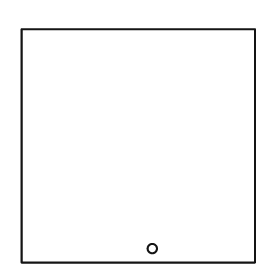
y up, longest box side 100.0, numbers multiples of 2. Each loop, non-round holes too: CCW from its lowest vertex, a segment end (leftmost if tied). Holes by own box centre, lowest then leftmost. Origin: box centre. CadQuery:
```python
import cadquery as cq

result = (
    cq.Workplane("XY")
    .moveTo(-50.0, -50.0)
    .lineTo(50.0, -50.0)
    .lineTo(50.0, 50.0)
    .lineTo(-50.0, 50.0)
    .close()
    .moveTo(6.0, -44.0)
    .circle(2.0)
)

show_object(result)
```